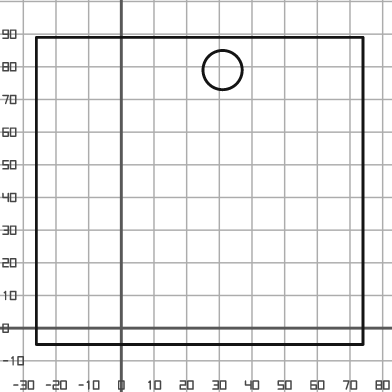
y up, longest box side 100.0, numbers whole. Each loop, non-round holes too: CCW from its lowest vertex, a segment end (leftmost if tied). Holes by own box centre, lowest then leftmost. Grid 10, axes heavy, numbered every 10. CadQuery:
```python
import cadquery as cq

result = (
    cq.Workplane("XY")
    .moveTo(-26.0, -5.0)
    .lineTo(74.0, -5.0)
    .lineTo(74.0, 89.0)
    .lineTo(-26.0, 89.0)
    .close()
    .moveTo(31.0, 79.0)
    .circle(6.0)
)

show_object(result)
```